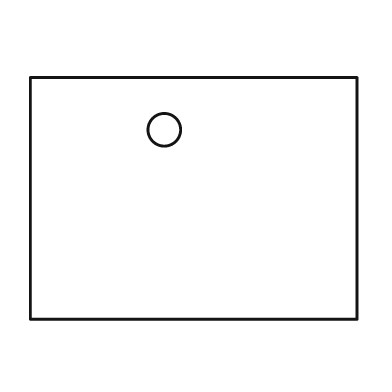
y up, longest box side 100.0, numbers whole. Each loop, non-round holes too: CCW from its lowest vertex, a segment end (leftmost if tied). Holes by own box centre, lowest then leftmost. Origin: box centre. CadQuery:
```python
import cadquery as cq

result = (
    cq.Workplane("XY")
    .moveTo(-50.0, -37.0)
    .lineTo(50.0, -37.0)
    .lineTo(50.0, 37.0)
    .lineTo(-50.0, 37.0)
    .close()
    .moveTo(-9.0, 21.0)
    .circle(5.0)
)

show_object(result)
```